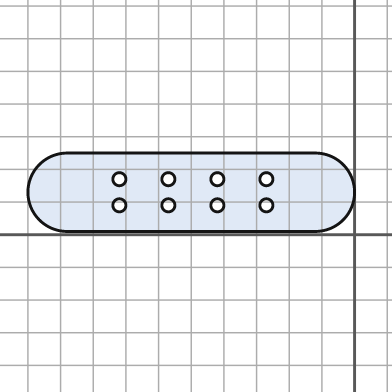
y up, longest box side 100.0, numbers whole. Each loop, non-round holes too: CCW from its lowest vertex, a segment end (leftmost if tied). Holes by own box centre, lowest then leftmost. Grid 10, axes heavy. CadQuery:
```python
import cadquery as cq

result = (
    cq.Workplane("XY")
    .moveTo(-88.0, 1.0)
    .lineTo(-12.0, 1.0)
    .threePointArc((0.0, 13.0), (-12.0, 25.0))
    .lineTo(-88.0, 25.0)
    .threePointArc((-100.0, 13.0), (-88.0, 1.0))
    .close()
    .moveTo(-72.0, 9.0)
    .circle(2.0)
    .moveTo(-57.0, 9.0)
    .circle(2.0)
    .moveTo(-42.0, 9.0)
    .circle(2.0)
    .moveTo(-27.0, 9.0)
    .circle(2.0)
    .moveTo(-72.0, 17.0)
    .circle(2.0)
    .moveTo(-57.0, 17.0)
    .circle(2.0)
    .moveTo(-42.0, 17.0)
    .circle(2.0)
    .moveTo(-27.0, 17.0)
    .circle(2.0)
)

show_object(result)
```